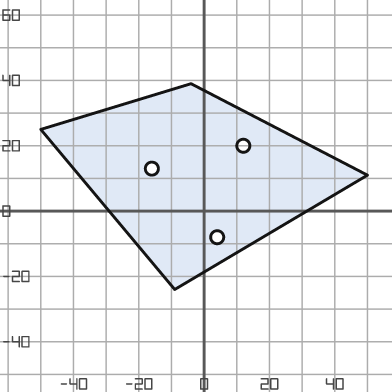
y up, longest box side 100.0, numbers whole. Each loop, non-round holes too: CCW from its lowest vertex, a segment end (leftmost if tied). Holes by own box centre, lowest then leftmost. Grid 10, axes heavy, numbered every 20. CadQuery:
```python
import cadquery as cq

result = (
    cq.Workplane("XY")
    .moveTo(-9.0, -24.0)
    .lineTo(50.0, 11.0)
    .lineTo(-4.0, 39.0)
    .lineTo(-50.0, 25.0)
    .close()
    .moveTo(4.0, -8.0)
    .circle(2.0)
    .moveTo(-16.0, 13.0)
    .circle(2.0)
    .moveTo(12.0, 20.0)
    .circle(2.0)
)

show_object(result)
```